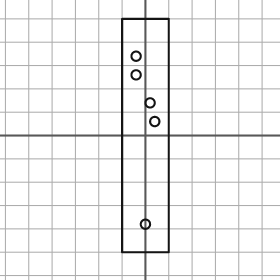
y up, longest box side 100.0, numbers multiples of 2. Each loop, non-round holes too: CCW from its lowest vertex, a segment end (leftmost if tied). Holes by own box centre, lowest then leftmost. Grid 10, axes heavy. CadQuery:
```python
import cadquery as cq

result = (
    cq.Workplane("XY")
    .moveTo(-10.0, -50.0)
    .lineTo(10.0, -50.0)
    .lineTo(10.0, 50.0)
    .lineTo(-10.0, 50.0)
    .close()
    .moveTo(0.0, -38.0)
    .circle(2.0)
    .moveTo(4.0, 6.0)
    .circle(2.0)
    .moveTo(2.0, 14.0)
    .circle(2.0)
    .moveTo(-4.0, 26.0)
    .circle(2.0)
    .moveTo(-4.0, 34.0)
    .circle(2.0)
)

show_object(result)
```